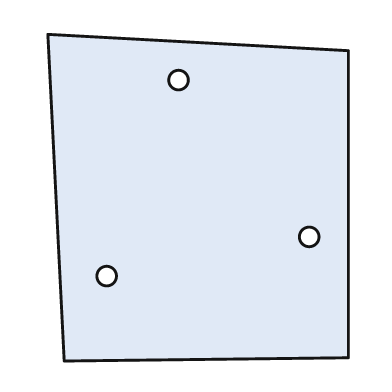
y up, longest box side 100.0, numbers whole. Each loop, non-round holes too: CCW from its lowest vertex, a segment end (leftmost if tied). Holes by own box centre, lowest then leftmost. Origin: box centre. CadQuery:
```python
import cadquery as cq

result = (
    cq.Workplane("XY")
    .moveTo(-41.0, -50.0)
    .lineTo(46.0, -49.0)
    .lineTo(46.0, 45.0)
    .lineTo(-46.0, 50.0)
    .close()
    .moveTo(-28.0, -24.0)
    .circle(3.0)
    .moveTo(34.0, -12.0)
    .circle(3.0)
    .moveTo(-6.0, 36.0)
    .circle(3.0)
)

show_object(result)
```